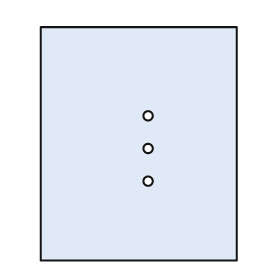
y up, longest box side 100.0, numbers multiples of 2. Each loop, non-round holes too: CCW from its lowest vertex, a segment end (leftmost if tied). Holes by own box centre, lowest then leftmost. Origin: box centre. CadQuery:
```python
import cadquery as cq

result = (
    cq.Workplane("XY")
    .moveTo(-42.0, -50.0)
    .lineTo(42.0, -50.0)
    .lineTo(42.0, 50.0)
    .lineTo(-42.0, 50.0)
    .close()
    .moveTo(4.0, -16.0)
    .circle(2.0)
    .moveTo(4.0, -2.0)
    .circle(2.0)
    .moveTo(4.0, 12.0)
    .circle(2.0)
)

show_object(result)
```